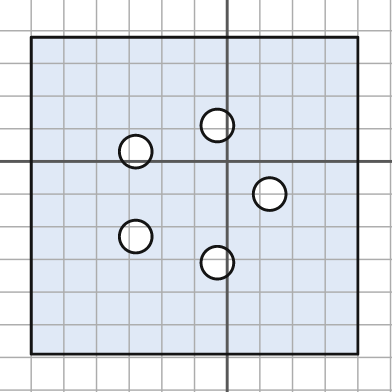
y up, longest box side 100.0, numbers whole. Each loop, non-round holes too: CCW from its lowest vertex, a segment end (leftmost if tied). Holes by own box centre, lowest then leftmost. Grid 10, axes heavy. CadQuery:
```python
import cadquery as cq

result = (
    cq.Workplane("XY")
    .moveTo(-60.0, -59.0)
    .lineTo(40.0, -59.0)
    .lineTo(40.0, 38.0)
    .lineTo(-60.0, 38.0)
    .close()
    .moveTo(-3.0, -31.0)
    .circle(5.0)
    .moveTo(-28.0, -23.0)
    .circle(5.0)
    .moveTo(13.0, -10.0)
    .circle(5.0)
    .moveTo(-28.0, 3.0)
    .circle(5.0)
    .moveTo(-3.0, 11.0)
    .circle(5.0)
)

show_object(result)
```